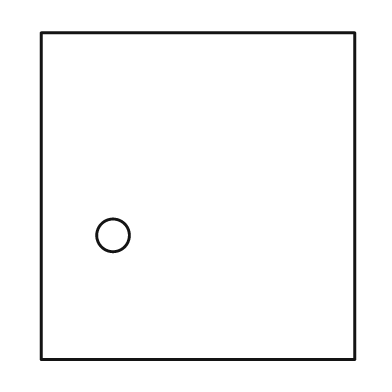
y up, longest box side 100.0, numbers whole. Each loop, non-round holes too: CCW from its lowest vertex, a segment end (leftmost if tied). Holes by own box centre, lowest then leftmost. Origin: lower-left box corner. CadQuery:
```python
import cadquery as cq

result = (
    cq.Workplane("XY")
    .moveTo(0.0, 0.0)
    .lineTo(96.0, 0.0)
    .lineTo(96.0, 100.0)
    .lineTo(0.0, 100.0)
    .close()
    .moveTo(22.0, 38.0)
    .circle(5.0)
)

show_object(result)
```